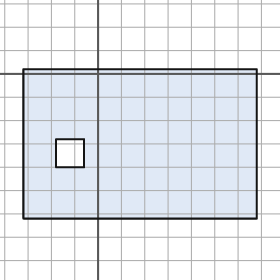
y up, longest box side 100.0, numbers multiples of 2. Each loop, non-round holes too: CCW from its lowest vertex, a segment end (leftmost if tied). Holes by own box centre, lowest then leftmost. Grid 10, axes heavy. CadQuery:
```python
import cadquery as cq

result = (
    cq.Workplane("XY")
    .moveTo(-32.0, -62.0)
    .lineTo(68.0, -62.0)
    .lineTo(68.0, 2.0)
    .lineTo(-32.0, 2.0)
    .close()
    .moveTo(-18.0, -40.0)
    .lineTo(-6.0, -40.0)
    .lineTo(-6.0, -28.0)
    .lineTo(-18.0, -28.0)
    .close()
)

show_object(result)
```